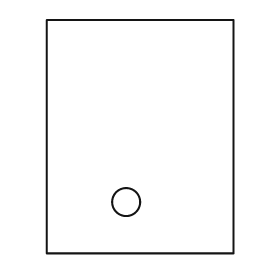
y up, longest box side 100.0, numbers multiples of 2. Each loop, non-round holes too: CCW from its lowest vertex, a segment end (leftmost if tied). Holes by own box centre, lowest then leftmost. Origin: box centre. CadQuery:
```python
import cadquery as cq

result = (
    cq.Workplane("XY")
    .moveTo(-40.0, -50.0)
    .lineTo(40.0, -50.0)
    .lineTo(40.0, 50.0)
    .lineTo(-40.0, 50.0)
    .close()
    .moveTo(-6.0, -28.0)
    .circle(6.0)
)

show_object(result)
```